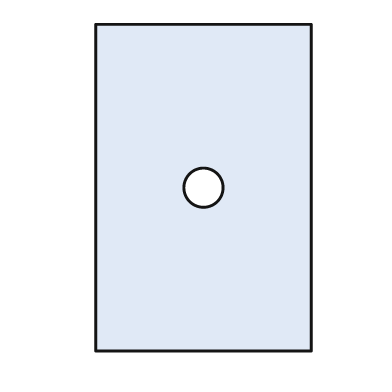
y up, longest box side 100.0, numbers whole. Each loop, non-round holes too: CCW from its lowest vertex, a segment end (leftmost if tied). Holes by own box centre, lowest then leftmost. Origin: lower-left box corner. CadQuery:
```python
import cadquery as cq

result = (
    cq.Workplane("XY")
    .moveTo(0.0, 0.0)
    .lineTo(66.0, 0.0)
    .lineTo(66.0, 100.0)
    .lineTo(0.0, 100.0)
    .close()
    .moveTo(33.0, 50.0)
    .circle(6.0)
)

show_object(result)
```